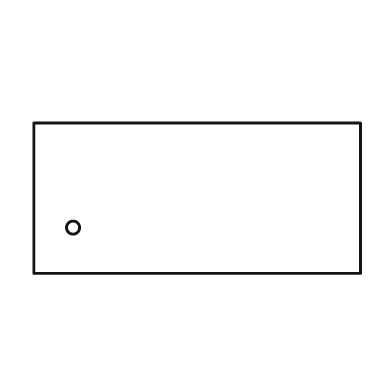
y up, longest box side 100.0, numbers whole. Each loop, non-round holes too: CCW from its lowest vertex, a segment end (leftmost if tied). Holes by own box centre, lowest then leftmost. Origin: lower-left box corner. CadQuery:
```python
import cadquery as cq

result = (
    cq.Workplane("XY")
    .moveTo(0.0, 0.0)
    .lineTo(100.0, 0.0)
    .lineTo(100.0, 46.0)
    .lineTo(0.0, 46.0)
    .close()
    .moveTo(12.0, 14.0)
    .circle(2.0)
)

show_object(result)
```